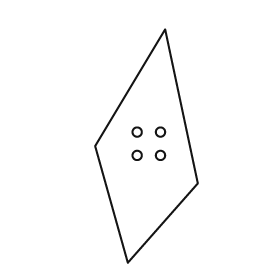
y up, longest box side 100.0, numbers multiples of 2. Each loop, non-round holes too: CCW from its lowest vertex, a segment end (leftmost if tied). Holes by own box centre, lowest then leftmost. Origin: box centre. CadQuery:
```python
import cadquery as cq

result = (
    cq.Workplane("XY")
    .moveTo(-8.0, -50.0)
    .lineTo(22.0, -16.0)
    .lineTo(8.0, 50.0)
    .lineTo(-22.0, 0.0)
    .close()
    .moveTo(-4.0, -4.0)
    .circle(2.0)
    .moveTo(6.0, -4.0)
    .circle(2.0)
    .moveTo(-4.0, 6.0)
    .circle(2.0)
    .moveTo(6.0, 6.0)
    .circle(2.0)
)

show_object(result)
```